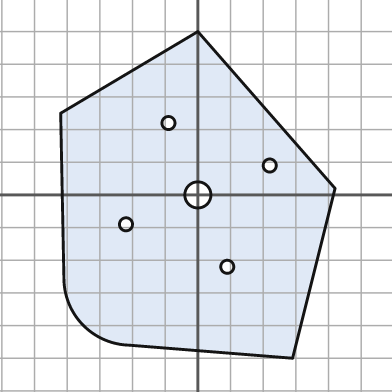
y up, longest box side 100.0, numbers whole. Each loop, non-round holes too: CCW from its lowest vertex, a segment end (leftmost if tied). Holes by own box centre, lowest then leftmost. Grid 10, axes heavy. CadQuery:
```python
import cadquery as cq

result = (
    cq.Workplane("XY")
    .moveTo(29.0, -50.0)
    .lineTo(42.0, 2.0)
    .lineTo(0.0, 50.0)
    .lineTo(-42.0, 25.0)
    .lineTo(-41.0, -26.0)
    .threePointArc((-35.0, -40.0), (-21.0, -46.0))
    .close()
    .moveTo(9.0, -22.0)
    .circle(2.0)
    .moveTo(-22.0, -9.0)
    .circle(2.0)
    .moveTo(0.0, 0.0)
    .circle(4.0)
    .moveTo(22.0, 9.0)
    .circle(2.0)
    .moveTo(-9.0, 22.0)
    .circle(2.0)
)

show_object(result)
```